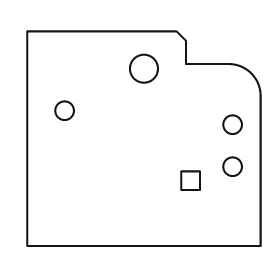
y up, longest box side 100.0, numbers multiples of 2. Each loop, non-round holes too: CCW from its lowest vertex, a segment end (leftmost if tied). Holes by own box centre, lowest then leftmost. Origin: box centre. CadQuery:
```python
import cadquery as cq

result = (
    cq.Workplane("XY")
    .moveTo(-50.0, -46.0)
    .lineTo(50.0, -46.0)
    .lineTo(50.0, 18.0)
    .threePointArc((46.0, 28.0), (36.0, 32.0))
    .lineTo(18.0, 32.0)
    .lineTo(18.0, 42.0)
    .lineTo(14.0, 46.0)
    .lineTo(-50.0, 46.0)
    .close()
    .moveTo(16.0, -22.0)
    .lineTo(24.0, -22.0)
    .lineTo(24.0, -14.0)
    .lineTo(16.0, -14.0)
    .close()
    .moveTo(38.0, -12.0)
    .circle(4.0)
    .moveTo(38.0, 6.0)
    .circle(4.0)
    .moveTo(-34.0, 12.0)
    .circle(4.0)
    .moveTo(0.0, 30.0)
    .circle(6.0)
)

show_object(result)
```